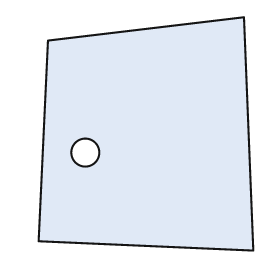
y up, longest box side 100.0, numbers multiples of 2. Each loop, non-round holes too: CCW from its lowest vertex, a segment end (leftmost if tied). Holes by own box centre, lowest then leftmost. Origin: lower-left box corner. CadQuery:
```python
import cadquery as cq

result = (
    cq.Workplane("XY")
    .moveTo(92.0, 0.0)
    .lineTo(88.0, 100.0)
    .lineTo(4.0, 90.0)
    .lineTo(0.0, 4.0)
    .close()
    .moveTo(20.0, 42.0)
    .circle(6.0)
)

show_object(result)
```